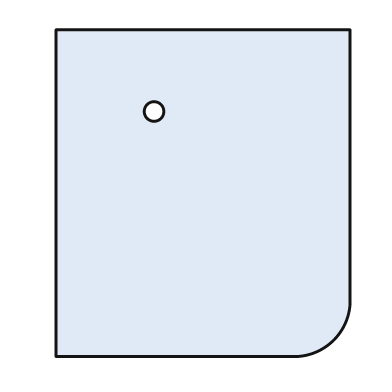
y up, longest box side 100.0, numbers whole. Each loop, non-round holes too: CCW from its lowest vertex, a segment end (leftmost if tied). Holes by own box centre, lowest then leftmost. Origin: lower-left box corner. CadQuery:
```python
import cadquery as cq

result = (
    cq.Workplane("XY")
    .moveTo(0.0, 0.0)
    .lineTo(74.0, 0.0)
    .threePointArc((85.0, 5.0), (90.0, 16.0))
    .lineTo(90.0, 100.0)
    .lineTo(0.0, 100.0)
    .close()
    .moveTo(30.0, 75.0)
    .circle(3.0)
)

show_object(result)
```